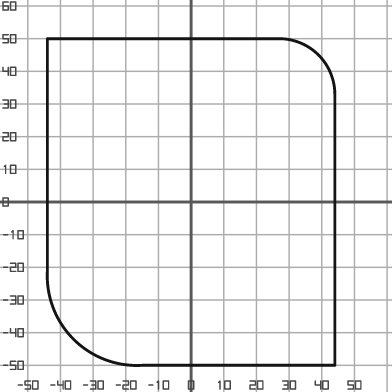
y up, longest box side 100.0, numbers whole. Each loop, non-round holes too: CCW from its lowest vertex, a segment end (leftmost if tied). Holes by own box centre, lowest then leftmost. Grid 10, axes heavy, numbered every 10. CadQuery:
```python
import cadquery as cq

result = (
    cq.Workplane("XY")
    .moveTo(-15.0, -50.0)
    .lineTo(44.0, -50.0)
    .lineTo(44.0, 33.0)
    .threePointArc((39.0, 45.0), (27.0, 50.0))
    .lineTo(-44.0, 50.0)
    .lineTo(-44.0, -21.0)
    .threePointArc((-36.0, -42.0), (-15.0, -50.0))
    .close()
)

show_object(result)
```